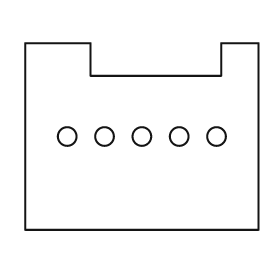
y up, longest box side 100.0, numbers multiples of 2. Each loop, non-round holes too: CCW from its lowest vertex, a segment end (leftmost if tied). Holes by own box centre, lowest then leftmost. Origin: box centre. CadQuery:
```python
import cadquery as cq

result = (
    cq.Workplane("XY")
    .moveTo(-50.0, -40.0)
    .lineTo(50.0, -40.0)
    .lineTo(50.0, 40.0)
    .lineTo(34.0, 40.0)
    .lineTo(34.0, 26.0)
    .lineTo(-22.0, 26.0)
    .lineTo(-22.0, 40.0)
    .lineTo(-50.0, 40.0)
    .close()
    .moveTo(-32.0, 0.0)
    .circle(4.0)
    .moveTo(-16.0, 0.0)
    .circle(4.0)
    .moveTo(0.0, 0.0)
    .circle(4.0)
    .moveTo(16.0, 0.0)
    .circle(4.0)
    .moveTo(32.0, 0.0)
    .circle(4.0)
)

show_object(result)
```